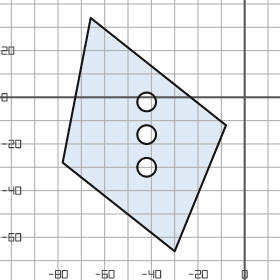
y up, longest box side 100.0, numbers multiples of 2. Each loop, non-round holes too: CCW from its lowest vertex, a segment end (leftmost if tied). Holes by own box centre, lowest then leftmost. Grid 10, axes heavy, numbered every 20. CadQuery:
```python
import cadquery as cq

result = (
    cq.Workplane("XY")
    .moveTo(-30.0, -66.0)
    .lineTo(-8.0, -12.0)
    .lineTo(-66.0, 34.0)
    .lineTo(-78.0, -28.0)
    .close()
    .moveTo(-42.0, -30.0)
    .circle(4.0)
    .moveTo(-42.0, -16.0)
    .circle(4.0)
    .moveTo(-42.0, -2.0)
    .circle(4.0)
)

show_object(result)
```